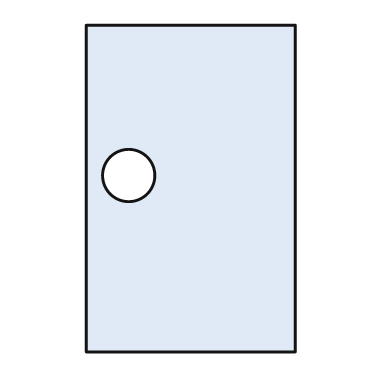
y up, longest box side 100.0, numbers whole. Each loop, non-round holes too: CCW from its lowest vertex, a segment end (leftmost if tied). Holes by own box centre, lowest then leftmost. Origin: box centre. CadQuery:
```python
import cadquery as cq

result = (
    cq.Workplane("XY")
    .moveTo(-32.0, -50.0)
    .lineTo(32.0, -50.0)
    .lineTo(32.0, 50.0)
    .lineTo(-32.0, 50.0)
    .close()
    .moveTo(-19.0, 4.0)
    .circle(8.0)
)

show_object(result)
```